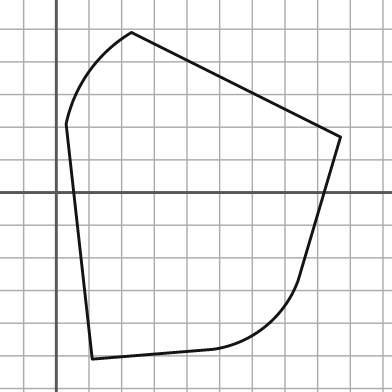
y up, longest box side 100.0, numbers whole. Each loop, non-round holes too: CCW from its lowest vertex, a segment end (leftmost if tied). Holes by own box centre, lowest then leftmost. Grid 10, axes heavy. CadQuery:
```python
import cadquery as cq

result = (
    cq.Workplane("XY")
    .moveTo(11.0, -51.0)
    .lineTo(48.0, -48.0)
    .threePointArc((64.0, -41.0), (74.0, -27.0))
    .lineTo(87.0, 17.0)
    .lineTo(23.0, 49.0)
    .threePointArc((10.0, 37.0), (3.0, 21.0))
    .close()
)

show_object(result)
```